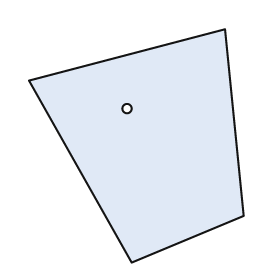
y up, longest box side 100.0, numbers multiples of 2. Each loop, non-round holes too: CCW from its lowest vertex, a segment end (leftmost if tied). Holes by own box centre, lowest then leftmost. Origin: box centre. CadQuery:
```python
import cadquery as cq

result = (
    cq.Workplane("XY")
    .moveTo(-2.0, -50.0)
    .lineTo(46.0, -30.0)
    .lineTo(38.0, 50.0)
    .lineTo(-46.0, 28.0)
    .close()
    .moveTo(-4.0, 16.0)
    .circle(2.0)
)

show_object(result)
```